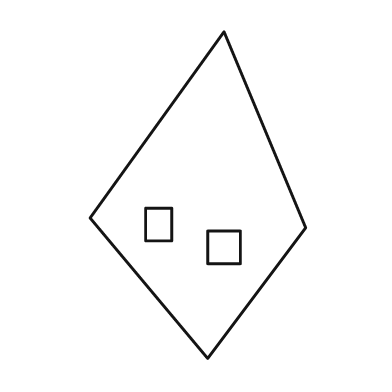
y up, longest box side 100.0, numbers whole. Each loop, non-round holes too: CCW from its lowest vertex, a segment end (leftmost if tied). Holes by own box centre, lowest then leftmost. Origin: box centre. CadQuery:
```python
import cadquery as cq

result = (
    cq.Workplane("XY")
    .moveTo(3.0, -50.0)
    .lineTo(33.0, -10.0)
    .lineTo(8.0, 50.0)
    .lineTo(-33.0, -7.0)
    .close()
    .moveTo(3.0, -21.0)
    .lineTo(13.0, -21.0)
    .lineTo(13.0, -11.0)
    .lineTo(3.0, -11.0)
    .close()
    .moveTo(-16.0, -14.0)
    .lineTo(-8.0, -14.0)
    .lineTo(-8.0, -4.0)
    .lineTo(-16.0, -4.0)
    .close()
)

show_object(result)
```